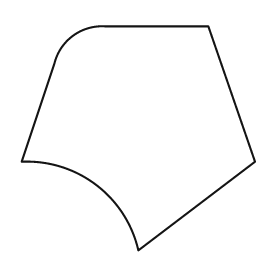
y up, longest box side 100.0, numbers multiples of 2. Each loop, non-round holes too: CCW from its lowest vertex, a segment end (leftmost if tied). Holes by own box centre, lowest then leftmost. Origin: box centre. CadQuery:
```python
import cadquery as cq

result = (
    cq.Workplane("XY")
    .moveTo(0.0, -48.0)
    .lineTo(50.0, -10.0)
    .lineTo(30.0, 48.0)
    .lineTo(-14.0, 48.0)
    .threePointArc((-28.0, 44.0), (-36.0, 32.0))
    .lineTo(-50.0, -10.0)
    .threePointArc((-18.0, -20.0), (0.0, -48.0))
    .close()
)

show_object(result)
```